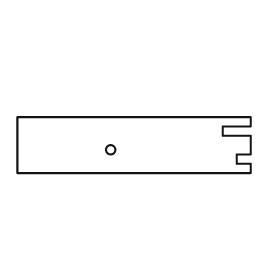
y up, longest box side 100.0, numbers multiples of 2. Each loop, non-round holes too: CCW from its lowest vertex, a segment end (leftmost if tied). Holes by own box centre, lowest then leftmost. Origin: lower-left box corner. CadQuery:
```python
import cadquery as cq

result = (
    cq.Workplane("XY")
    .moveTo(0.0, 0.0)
    .lineTo(100.0, 0.0)
    .lineTo(100.0, 4.0)
    .lineTo(94.0, 4.0)
    .lineTo(94.0, 8.0)
    .lineTo(100.0, 8.0)
    .lineTo(100.0, 16.0)
    .lineTo(88.0, 16.0)
    .lineTo(88.0, 20.0)
    .lineTo(100.0, 20.0)
    .lineTo(100.0, 24.0)
    .lineTo(0.0, 24.0)
    .close()
    .moveTo(40.0, 10.0)
    .circle(2.0)
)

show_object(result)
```